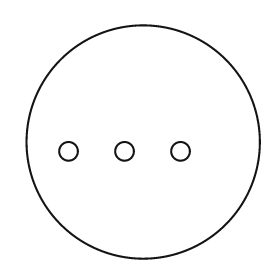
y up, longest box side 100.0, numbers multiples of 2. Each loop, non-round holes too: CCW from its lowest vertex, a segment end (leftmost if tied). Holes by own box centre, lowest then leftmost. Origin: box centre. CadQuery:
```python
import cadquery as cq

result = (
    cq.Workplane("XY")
    .moveTo(0.0, 0.0)
    .circle(50.0)
    .moveTo(-32.0, -4.0)
    .circle(4.0)
    .moveTo(-8.0, -4.0)
    .circle(4.0)
    .moveTo(16.0, -4.0)
    .circle(4.0)
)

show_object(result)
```